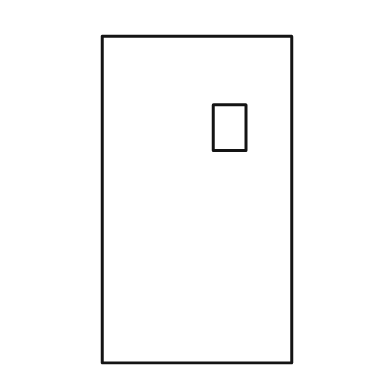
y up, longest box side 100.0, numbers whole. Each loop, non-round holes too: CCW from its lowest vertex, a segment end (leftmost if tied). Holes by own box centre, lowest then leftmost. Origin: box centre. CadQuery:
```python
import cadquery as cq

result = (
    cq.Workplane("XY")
    .moveTo(-29.0, -50.0)
    .lineTo(29.0, -50.0)
    .lineTo(29.0, 50.0)
    .lineTo(-29.0, 50.0)
    .close()
    .moveTo(5.0, 15.0)
    .lineTo(15.0, 15.0)
    .lineTo(15.0, 29.0)
    .lineTo(5.0, 29.0)
    .close()
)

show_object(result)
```